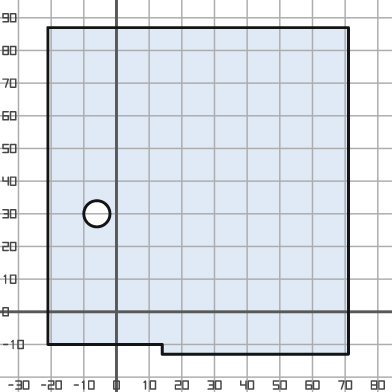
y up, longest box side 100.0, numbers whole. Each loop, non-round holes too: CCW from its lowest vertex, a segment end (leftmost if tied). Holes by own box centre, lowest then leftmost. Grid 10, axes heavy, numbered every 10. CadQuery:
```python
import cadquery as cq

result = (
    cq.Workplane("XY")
    .moveTo(14.0, -13.0)
    .lineTo(71.0, -13.0)
    .lineTo(71.0, 87.0)
    .lineTo(-21.0, 87.0)
    .lineTo(-21.0, -10.0)
    .lineTo(14.0, -10.0)
    .close()
    .moveTo(-6.0, 30.0)
    .circle(4.0)
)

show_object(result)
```